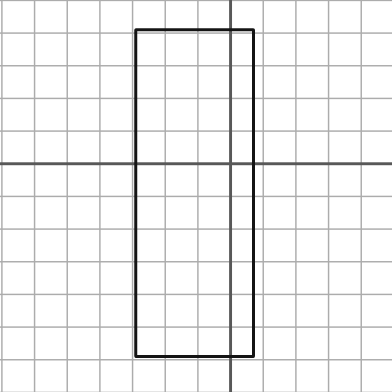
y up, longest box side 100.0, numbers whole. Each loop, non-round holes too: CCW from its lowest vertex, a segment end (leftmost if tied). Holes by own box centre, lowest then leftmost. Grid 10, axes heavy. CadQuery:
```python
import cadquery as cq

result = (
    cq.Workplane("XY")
    .moveTo(-29.0, -59.0)
    .lineTo(7.0, -59.0)
    .lineTo(7.0, 41.0)
    .lineTo(-29.0, 41.0)
    .close()
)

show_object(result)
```